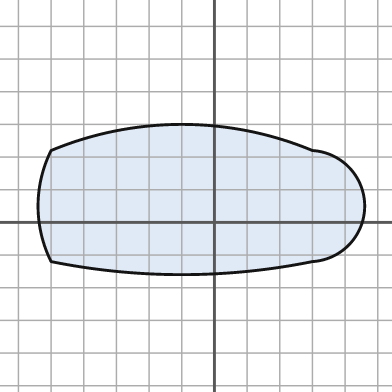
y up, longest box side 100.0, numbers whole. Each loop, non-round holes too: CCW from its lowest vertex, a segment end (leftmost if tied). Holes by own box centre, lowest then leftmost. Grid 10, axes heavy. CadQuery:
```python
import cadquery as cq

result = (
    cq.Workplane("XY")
    .moveTo(-50.0, -12.0)
    .threePointArc((-10.0, -16.0), (30.0, -12.0))
    .threePointArc((46.0, 5.0), (30.0, 22.0))
    .threePointArc((-10.0, 30.0), (-50.0, 22.0))
    .threePointArc((-54.0, 5.0), (-50.0, -12.0))
    .close()
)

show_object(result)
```